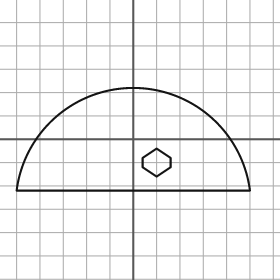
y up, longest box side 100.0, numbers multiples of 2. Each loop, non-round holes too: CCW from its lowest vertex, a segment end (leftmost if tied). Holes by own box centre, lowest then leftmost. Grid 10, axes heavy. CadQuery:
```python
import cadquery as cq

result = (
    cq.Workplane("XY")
    .moveTo(-50.0, -22.0)
    .lineTo(50.0, -22.0)
    .threePointArc((0.0, 22.0), (-50.0, -22.0))
    .close()
    .moveTo(10.0, -16.0)
    .lineTo(16.0, -12.0)
    .lineTo(16.0, -8.0)
    .lineTo(10.0, -4.0)
    .lineTo(4.0, -8.0)
    .lineTo(4.0, -12.0)
    .close()
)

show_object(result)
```